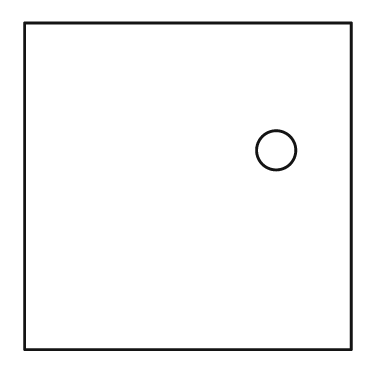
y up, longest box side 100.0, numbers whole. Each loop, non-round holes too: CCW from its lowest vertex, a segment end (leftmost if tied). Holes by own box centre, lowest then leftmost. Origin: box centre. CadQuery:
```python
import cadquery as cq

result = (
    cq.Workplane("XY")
    .moveTo(-50.0, -50.0)
    .lineTo(50.0, -50.0)
    .lineTo(50.0, 50.0)
    .lineTo(-50.0, 50.0)
    .close()
    .moveTo(27.0, 11.0)
    .circle(6.0)
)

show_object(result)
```